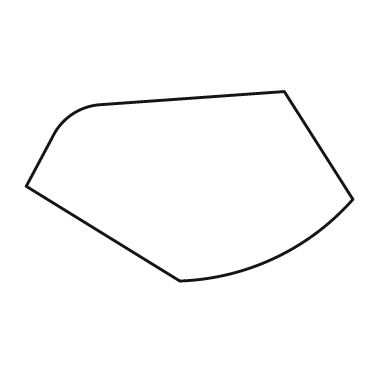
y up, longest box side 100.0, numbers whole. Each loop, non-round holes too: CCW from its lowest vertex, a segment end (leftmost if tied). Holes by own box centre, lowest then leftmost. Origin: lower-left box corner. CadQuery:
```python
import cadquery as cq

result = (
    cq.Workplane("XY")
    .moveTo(47.0, 0.0)
    .threePointArc((76.0, 7.0), (100.0, 25.0))
    .lineTo(79.0, 58.0)
    .lineTo(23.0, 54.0)
    .threePointArc((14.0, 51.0), (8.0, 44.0))
    .lineTo(0.0, 29.0)
    .close()
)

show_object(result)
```